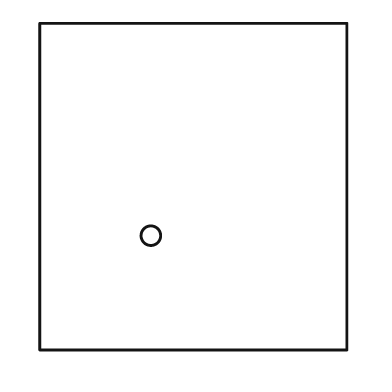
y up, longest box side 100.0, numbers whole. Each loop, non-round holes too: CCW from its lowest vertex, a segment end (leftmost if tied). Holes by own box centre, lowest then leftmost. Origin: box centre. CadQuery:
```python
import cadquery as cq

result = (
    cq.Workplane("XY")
    .moveTo(-47.0, -50.0)
    .lineTo(47.0, -50.0)
    .lineTo(47.0, 50.0)
    .lineTo(-47.0, 50.0)
    .close()
    .moveTo(-13.0, -15.0)
    .circle(3.0)
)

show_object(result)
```